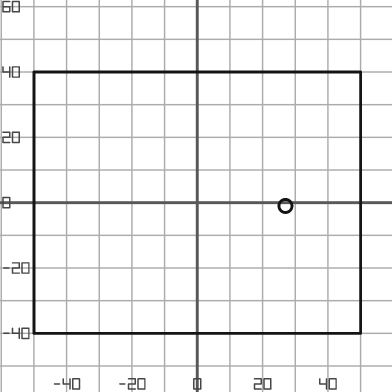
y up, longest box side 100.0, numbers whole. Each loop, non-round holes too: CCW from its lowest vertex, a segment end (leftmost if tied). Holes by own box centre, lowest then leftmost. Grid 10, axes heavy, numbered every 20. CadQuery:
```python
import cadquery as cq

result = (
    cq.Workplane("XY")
    .moveTo(-50.0, -40.0)
    .lineTo(50.0, -40.0)
    .lineTo(50.0, 40.0)
    .lineTo(-50.0, 40.0)
    .close()
    .moveTo(27.0, -1.0)
    .circle(2.0)
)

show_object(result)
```